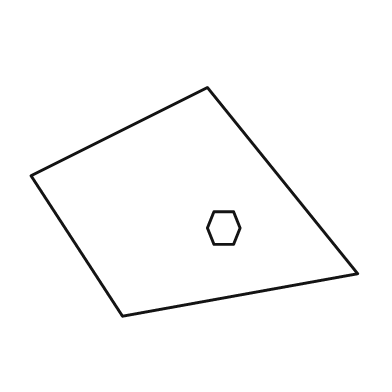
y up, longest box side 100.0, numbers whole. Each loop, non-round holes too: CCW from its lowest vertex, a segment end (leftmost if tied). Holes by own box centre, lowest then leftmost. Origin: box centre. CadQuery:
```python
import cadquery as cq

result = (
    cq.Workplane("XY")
    .moveTo(-22.0, -35.0)
    .lineTo(50.0, -22.0)
    .lineTo(4.0, 35.0)
    .lineTo(-50.0, 8.0)
    .close()
    .moveTo(6.0, -13.0)
    .lineTo(12.0, -13.0)
    .lineTo(14.0, -8.0)
    .lineTo(12.0, -3.0)
    .lineTo(6.0, -3.0)
    .lineTo(4.0, -8.0)
    .close()
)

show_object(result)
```